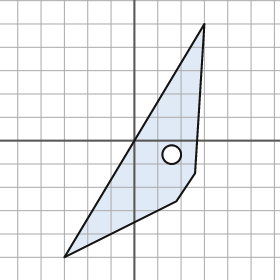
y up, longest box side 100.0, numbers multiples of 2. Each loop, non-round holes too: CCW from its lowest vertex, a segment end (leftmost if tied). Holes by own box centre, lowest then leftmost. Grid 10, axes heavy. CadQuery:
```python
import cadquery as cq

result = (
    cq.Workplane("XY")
    .moveTo(-30.0, -50.0)
    .lineTo(18.0, -26.0)
    .lineTo(26.0, -14.0)
    .lineTo(30.0, 50.0)
    .close()
    .moveTo(16.0, -6.0)
    .circle(4.0)
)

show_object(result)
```